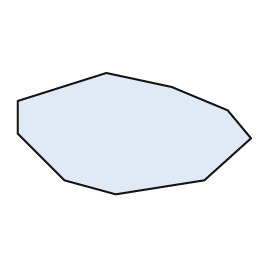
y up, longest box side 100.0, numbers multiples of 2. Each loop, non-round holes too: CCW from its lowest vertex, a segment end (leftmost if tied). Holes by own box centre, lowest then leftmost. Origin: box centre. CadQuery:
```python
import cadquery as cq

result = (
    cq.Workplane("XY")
    .moveTo(-8.0, -26.0)
    .lineTo(30.0, -20.0)
    .lineTo(50.0, -2.0)
    .lineTo(40.0, 10.0)
    .lineTo(16.0, 20.0)
    .lineTo(-12.0, 26.0)
    .lineTo(-50.0, 14.0)
    .lineTo(-50.0, 0.0)
    .lineTo(-30.0, -20.0)
    .close()
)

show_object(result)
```